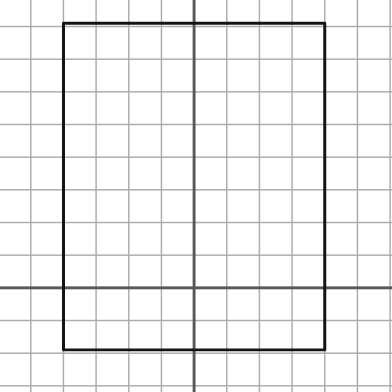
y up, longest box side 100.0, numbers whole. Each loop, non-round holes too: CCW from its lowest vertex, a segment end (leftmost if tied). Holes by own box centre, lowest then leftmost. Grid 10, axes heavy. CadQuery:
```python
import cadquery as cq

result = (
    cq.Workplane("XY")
    .moveTo(-40.0, -19.0)
    .lineTo(40.0, -19.0)
    .lineTo(40.0, 81.0)
    .lineTo(-40.0, 81.0)
    .close()
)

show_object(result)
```